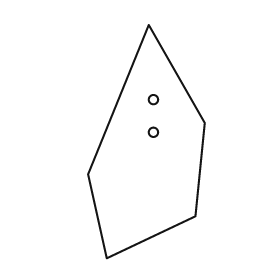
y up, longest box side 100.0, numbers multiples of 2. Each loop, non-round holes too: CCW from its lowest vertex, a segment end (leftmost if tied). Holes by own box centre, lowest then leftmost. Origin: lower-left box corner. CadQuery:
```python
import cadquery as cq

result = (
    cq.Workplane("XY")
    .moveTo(8.0, 0.0)
    .lineTo(46.0, 18.0)
    .lineTo(50.0, 58.0)
    .lineTo(26.0, 100.0)
    .lineTo(0.0, 36.0)
    .close()
    .moveTo(28.0, 54.0)
    .circle(2.0)
    .moveTo(28.0, 68.0)
    .circle(2.0)
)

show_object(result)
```